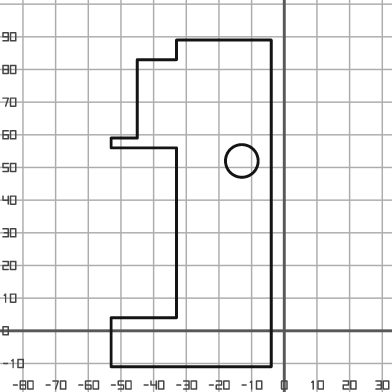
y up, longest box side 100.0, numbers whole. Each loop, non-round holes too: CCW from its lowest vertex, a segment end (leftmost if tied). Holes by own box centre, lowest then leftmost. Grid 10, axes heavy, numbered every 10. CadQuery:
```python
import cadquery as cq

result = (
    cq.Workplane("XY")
    .moveTo(-53.0, -11.0)
    .lineTo(-4.0, -11.0)
    .lineTo(-4.0, 89.0)
    .lineTo(-33.0, 89.0)
    .lineTo(-33.0, 83.0)
    .lineTo(-45.0, 83.0)
    .lineTo(-45.0, 59.0)
    .lineTo(-53.0, 59.0)
    .lineTo(-53.0, 56.0)
    .lineTo(-33.0, 56.0)
    .lineTo(-33.0, 4.0)
    .lineTo(-53.0, 4.0)
    .close()
    .moveTo(-13.0, 52.0)
    .circle(5.0)
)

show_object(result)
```